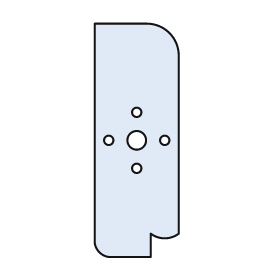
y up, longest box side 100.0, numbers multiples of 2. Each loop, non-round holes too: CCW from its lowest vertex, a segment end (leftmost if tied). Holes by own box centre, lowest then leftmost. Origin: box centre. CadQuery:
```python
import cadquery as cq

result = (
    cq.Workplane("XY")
    .moveTo(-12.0, -50.0)
    .lineTo(6.0, -50.0)
    .lineTo(6.0, -40.0)
    .threePointArc((12.0, -42.0), (18.0, -40.0))
    .lineTo(18.0, 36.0)
    .threePointArc((14.0, 46.0), (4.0, 50.0))
    .lineTo(-18.0, 50.0)
    .lineTo(-18.0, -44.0)
    .threePointArc((-16.0, -48.0), (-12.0, -50.0))
    .close()
    .moveTo(0.0, -12.0)
    .circle(2.0)
    .moveTo(-12.0, 0.0)
    .circle(2.0)
    .moveTo(0.0, 0.0)
    .circle(4.0)
    .moveTo(12.0, 0.0)
    .circle(2.0)
    .moveTo(0.0, 12.0)
    .circle(2.0)
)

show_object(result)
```